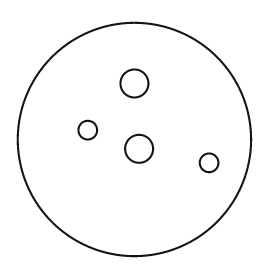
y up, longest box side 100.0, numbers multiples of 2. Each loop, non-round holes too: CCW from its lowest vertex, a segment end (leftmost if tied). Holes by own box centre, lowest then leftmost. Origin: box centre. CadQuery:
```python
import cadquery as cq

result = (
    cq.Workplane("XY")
    .moveTo(0.0, 0.0)
    .circle(50.0)
    .moveTo(32.0, -10.0)
    .circle(4.0)
    .moveTo(2.0, -4.0)
    .circle(6.0)
    .moveTo(-20.0, 4.0)
    .circle(4.0)
    .moveTo(0.0, 24.0)
    .circle(6.0)
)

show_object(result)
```